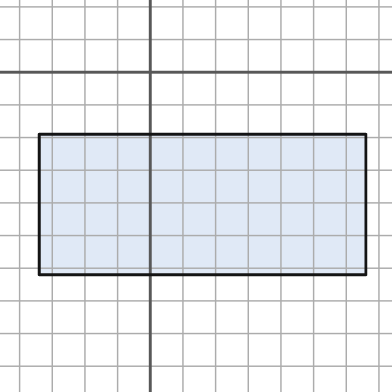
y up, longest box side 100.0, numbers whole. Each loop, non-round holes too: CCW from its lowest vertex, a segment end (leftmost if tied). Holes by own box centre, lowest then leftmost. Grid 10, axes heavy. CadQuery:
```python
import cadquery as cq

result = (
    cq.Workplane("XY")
    .moveTo(-34.0, -62.0)
    .lineTo(66.0, -62.0)
    .lineTo(66.0, -19.0)
    .lineTo(-34.0, -19.0)
    .close()
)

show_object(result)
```